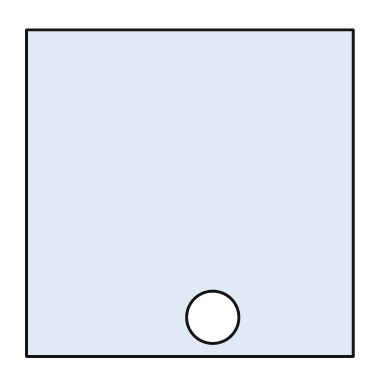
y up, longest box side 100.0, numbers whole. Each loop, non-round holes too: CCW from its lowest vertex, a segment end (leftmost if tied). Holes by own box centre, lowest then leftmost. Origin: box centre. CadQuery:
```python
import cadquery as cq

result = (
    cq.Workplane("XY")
    .moveTo(-50.0, -50.0)
    .lineTo(50.0, -50.0)
    .lineTo(50.0, 50.0)
    .lineTo(-50.0, 50.0)
    .close()
    .moveTo(7.0, -38.0)
    .circle(8.0)
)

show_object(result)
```